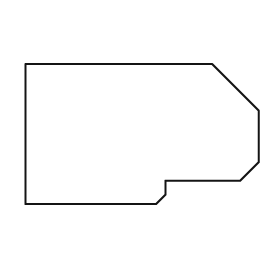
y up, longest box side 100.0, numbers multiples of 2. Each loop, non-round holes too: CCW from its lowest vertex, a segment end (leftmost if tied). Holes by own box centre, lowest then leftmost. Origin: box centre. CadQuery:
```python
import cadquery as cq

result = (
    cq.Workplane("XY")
    .moveTo(-50.0, -30.0)
    .lineTo(6.0, -30.0)
    .lineTo(10.0, -26.0)
    .lineTo(10.0, -20.0)
    .lineTo(42.0, -20.0)
    .lineTo(50.0, -12.0)
    .lineTo(50.0, 10.0)
    .lineTo(30.0, 30.0)
    .lineTo(-50.0, 30.0)
    .close()
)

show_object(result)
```